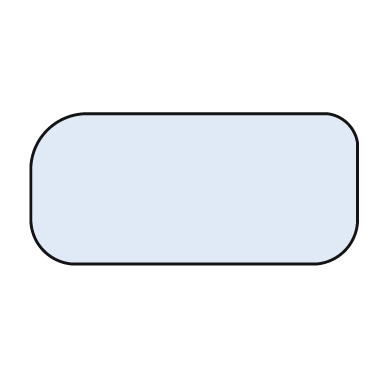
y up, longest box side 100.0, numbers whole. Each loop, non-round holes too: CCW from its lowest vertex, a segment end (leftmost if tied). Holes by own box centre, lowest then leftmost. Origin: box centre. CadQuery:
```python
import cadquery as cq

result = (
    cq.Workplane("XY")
    .moveTo(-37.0, -23.0)
    .lineTo(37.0, -23.0)
    .threePointArc((46.0, -19.0), (50.0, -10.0))
    .lineTo(50.0, 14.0)
    .threePointArc((47.0, 20.0), (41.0, 23.0))
    .lineTo(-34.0, 23.0)
    .threePointArc((-45.0, 18.0), (-50.0, 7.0))
    .lineTo(-50.0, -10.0)
    .threePointArc((-46.0, -19.0), (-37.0, -23.0))
    .close()
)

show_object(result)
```